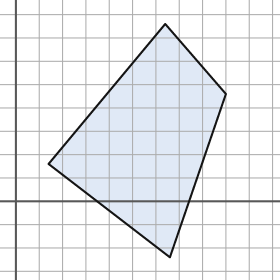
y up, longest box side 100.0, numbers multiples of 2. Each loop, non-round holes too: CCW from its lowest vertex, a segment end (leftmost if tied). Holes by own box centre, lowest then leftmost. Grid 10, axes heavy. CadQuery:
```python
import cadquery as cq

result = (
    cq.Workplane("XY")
    .moveTo(66.0, -24.0)
    .lineTo(90.0, 46.0)
    .lineTo(64.0, 76.0)
    .lineTo(14.0, 16.0)
    .close()
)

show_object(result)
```